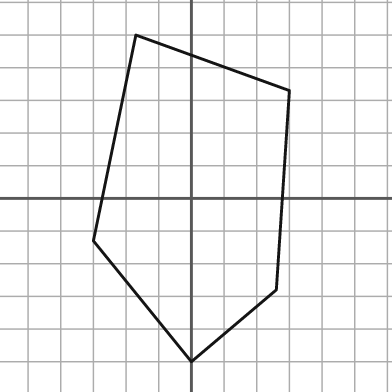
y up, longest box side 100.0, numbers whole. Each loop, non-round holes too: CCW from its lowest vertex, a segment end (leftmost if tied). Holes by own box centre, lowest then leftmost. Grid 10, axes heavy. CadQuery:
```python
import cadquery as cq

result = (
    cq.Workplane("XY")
    .moveTo(0.0, -50.0)
    .lineTo(26.0, -28.0)
    .lineTo(30.0, 33.0)
    .lineTo(-17.0, 50.0)
    .lineTo(-30.0, -13.0)
    .close()
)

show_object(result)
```